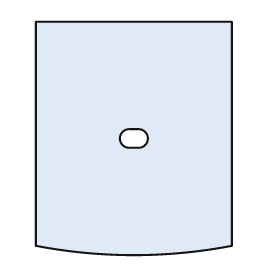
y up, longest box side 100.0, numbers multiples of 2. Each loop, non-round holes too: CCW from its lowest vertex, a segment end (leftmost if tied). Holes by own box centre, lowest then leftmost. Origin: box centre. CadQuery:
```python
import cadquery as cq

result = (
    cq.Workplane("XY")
    .moveTo(-42.0, -46.0)
    .threePointArc((0.0, -50.0), (42.0, -46.0))
    .lineTo(42.0, 50.0)
    .lineTo(-42.0, 50.0)
    .close()
    .moveTo(-2.0, -4.0)
    .lineTo(2.0, -4.0)
    .threePointArc((6.0, 0.0), (2.0, 4.0))
    .lineTo(-2.0, 4.0)
    .threePointArc((-6.0, 0.0), (-2.0, -4.0))
    .close()
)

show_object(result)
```